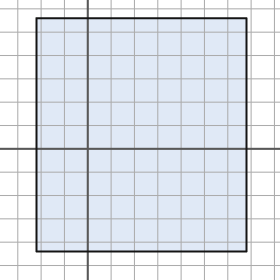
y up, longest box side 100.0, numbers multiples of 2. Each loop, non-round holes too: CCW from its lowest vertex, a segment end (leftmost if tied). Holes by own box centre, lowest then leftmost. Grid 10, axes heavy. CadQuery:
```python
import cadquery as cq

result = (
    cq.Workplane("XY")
    .moveTo(-22.0, -44.0)
    .lineTo(68.0, -44.0)
    .lineTo(68.0, 56.0)
    .lineTo(-22.0, 56.0)
    .close()
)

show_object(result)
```